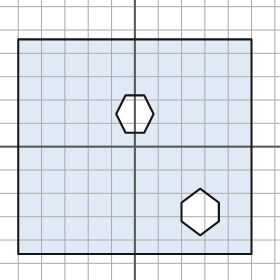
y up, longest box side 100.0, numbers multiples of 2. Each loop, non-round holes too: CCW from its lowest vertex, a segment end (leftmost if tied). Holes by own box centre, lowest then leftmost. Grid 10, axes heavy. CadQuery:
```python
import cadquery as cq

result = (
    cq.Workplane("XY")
    .moveTo(-50.0, -46.0)
    .lineTo(50.0, -46.0)
    .lineTo(50.0, 46.0)
    .lineTo(-50.0, 46.0)
    .close()
    .moveTo(28.0, -38.0)
    .lineTo(36.0, -32.0)
    .lineTo(36.0, -24.0)
    .lineTo(28.0, -18.0)
    .lineTo(20.0, -24.0)
    .lineTo(20.0, -32.0)
    .close()
    .moveTo(-4.0, 6.0)
    .lineTo(4.0, 6.0)
    .lineTo(8.0, 14.0)
    .lineTo(4.0, 22.0)
    .lineTo(-4.0, 22.0)
    .lineTo(-8.0, 14.0)
    .close()
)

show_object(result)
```